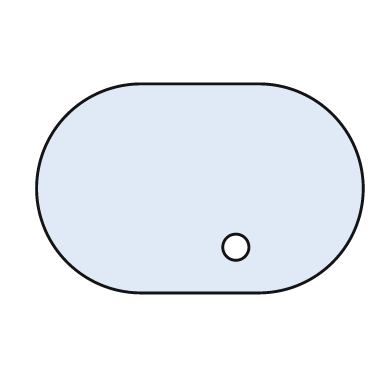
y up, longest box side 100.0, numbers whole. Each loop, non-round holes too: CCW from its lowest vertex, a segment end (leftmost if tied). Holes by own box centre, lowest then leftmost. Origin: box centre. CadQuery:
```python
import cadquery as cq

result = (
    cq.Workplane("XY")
    .moveTo(-18.0, -32.0)
    .lineTo(18.0, -32.0)
    .threePointArc((50.0, 0.0), (18.0, 32.0))
    .lineTo(-18.0, 32.0)
    .threePointArc((-50.0, 0.0), (-18.0, -32.0))
    .close()
    .moveTo(11.0, -18.0)
    .circle(4.0)
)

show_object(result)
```